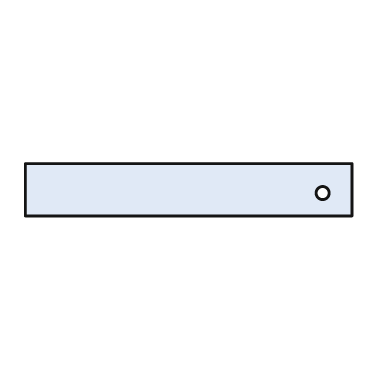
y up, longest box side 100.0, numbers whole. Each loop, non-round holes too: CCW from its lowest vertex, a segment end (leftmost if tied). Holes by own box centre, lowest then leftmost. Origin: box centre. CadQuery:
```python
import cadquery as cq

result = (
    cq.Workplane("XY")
    .moveTo(-50.0, -8.0)
    .lineTo(50.0, -8.0)
    .lineTo(50.0, 8.0)
    .lineTo(-50.0, 8.0)
    .close()
    .moveTo(41.0, -1.0)
    .circle(2.0)
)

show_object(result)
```